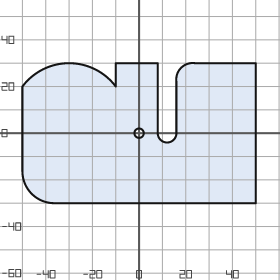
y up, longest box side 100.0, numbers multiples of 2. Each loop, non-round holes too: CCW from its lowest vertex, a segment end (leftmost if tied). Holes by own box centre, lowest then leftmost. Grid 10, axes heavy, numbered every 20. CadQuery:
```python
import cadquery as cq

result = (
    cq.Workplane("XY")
    .moveTo(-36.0, -30.0)
    .lineTo(50.0, -30.0)
    .lineTo(50.0, 30.0)
    .lineTo(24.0, 30.0)
    .threePointArc((18.0, 28.0), (16.0, 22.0))
    .lineTo(16.0, 0.0)
    .threePointArc((12.0, -4.0), (8.0, 0.0))
    .lineTo(8.0, 30.0)
    .lineTo(-10.0, 30.0)
    .lineTo(-10.0, 20.0)
    .threePointArc((-30.0, 30.0), (-50.0, 20.0))
    .lineTo(-50.0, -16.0)
    .threePointArc((-46.0, -26.0), (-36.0, -30.0))
    .close()
    .moveTo(0.0, 0.0)
    .circle(2.0)
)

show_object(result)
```